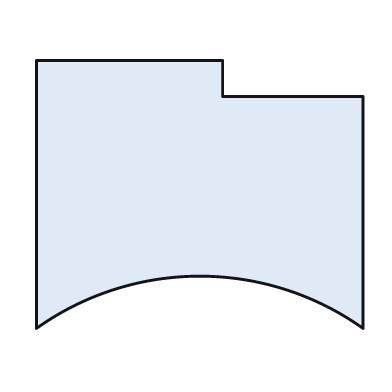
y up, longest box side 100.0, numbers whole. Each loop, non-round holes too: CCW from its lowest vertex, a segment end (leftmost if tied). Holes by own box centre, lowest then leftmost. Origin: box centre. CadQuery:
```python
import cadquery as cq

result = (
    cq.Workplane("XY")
    .moveTo(-50.0, -41.0)
    .threePointArc((0.0, -25.0), (50.0, -41.0))
    .lineTo(50.0, 30.0)
    .lineTo(7.0, 30.0)
    .lineTo(7.0, 41.0)
    .lineTo(-50.0, 41.0)
    .close()
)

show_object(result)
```